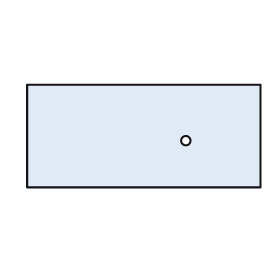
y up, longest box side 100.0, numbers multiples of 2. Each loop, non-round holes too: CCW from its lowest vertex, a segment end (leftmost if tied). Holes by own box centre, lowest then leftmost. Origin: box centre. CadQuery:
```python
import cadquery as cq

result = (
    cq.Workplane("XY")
    .moveTo(-50.0, -22.0)
    .lineTo(50.0, -22.0)
    .lineTo(50.0, 22.0)
    .lineTo(-50.0, 22.0)
    .close()
    .moveTo(18.0, -2.0)
    .circle(2.0)
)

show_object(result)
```